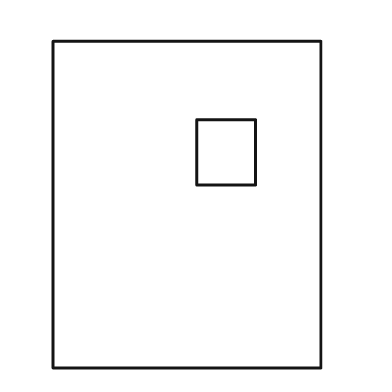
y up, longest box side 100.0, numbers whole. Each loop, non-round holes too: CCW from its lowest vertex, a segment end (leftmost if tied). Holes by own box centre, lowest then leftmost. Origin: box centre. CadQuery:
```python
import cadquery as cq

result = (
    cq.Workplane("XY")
    .moveTo(-41.0, -50.0)
    .lineTo(41.0, -50.0)
    .lineTo(41.0, 50.0)
    .lineTo(-41.0, 50.0)
    .close()
    .moveTo(3.0, 6.0)
    .lineTo(21.0, 6.0)
    .lineTo(21.0, 26.0)
    .lineTo(3.0, 26.0)
    .close()
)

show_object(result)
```